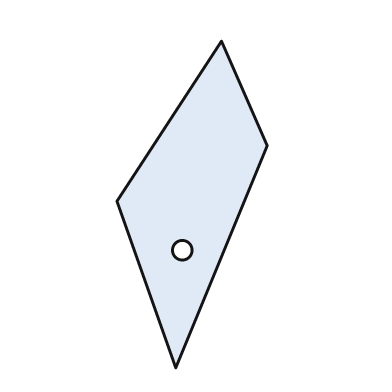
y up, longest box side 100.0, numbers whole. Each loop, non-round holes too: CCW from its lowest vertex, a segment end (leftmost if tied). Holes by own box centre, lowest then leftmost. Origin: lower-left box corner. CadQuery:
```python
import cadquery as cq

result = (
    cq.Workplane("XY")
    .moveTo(18.0, 0.0)
    .lineTo(46.0, 68.0)
    .lineTo(32.0, 100.0)
    .lineTo(0.0, 51.0)
    .close()
    .moveTo(20.0, 36.0)
    .circle(3.0)
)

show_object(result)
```